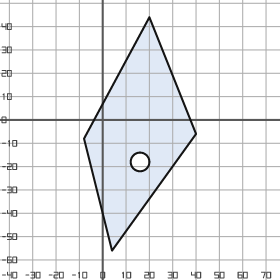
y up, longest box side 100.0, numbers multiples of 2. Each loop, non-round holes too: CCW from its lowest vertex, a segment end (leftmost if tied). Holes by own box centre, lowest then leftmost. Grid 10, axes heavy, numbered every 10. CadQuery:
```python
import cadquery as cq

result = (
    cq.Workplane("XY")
    .moveTo(4.0, -56.0)
    .lineTo(40.0, -6.0)
    .lineTo(20.0, 44.0)
    .lineTo(-8.0, -8.0)
    .close()
    .moveTo(16.0, -18.0)
    .circle(4.0)
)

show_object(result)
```